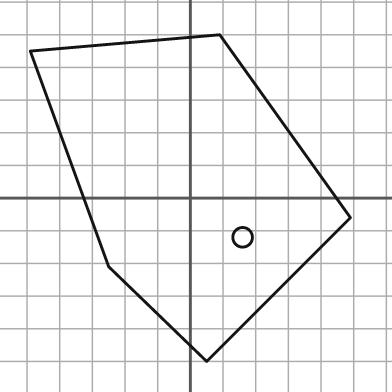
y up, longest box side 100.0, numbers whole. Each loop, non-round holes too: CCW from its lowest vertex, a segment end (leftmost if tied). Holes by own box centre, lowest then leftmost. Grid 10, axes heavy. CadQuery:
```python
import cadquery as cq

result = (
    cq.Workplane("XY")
    .moveTo(5.0, -50.0)
    .lineTo(49.0, -6.0)
    .lineTo(9.0, 50.0)
    .lineTo(-49.0, 45.0)
    .lineTo(-25.0, -21.0)
    .close()
    .moveTo(16.0, -12.0)
    .circle(3.0)
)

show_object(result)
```